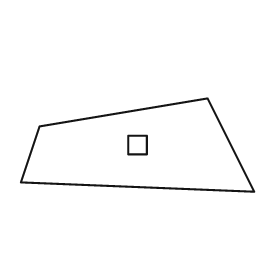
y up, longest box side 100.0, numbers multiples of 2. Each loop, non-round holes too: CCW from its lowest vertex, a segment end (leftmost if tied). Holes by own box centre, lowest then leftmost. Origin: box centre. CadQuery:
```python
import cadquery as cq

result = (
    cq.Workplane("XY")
    .moveTo(50.0, -20.0)
    .lineTo(30.0, 20.0)
    .lineTo(-42.0, 8.0)
    .lineTo(-50.0, -16.0)
    .close()
    .moveTo(-4.0, -4.0)
    .lineTo(4.0, -4.0)
    .lineTo(4.0, 4.0)
    .lineTo(-4.0, 4.0)
    .close()
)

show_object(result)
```